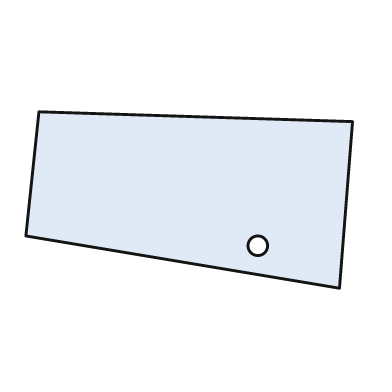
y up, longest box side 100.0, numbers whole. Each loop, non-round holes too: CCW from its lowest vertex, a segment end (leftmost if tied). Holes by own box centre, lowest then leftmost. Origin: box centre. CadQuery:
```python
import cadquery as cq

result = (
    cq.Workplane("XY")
    .moveTo(46.0, -27.0)
    .lineTo(50.0, 24.0)
    .lineTo(-46.0, 27.0)
    .lineTo(-50.0, -11.0)
    .close()
    .moveTo(21.0, -14.0)
    .circle(3.0)
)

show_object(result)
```